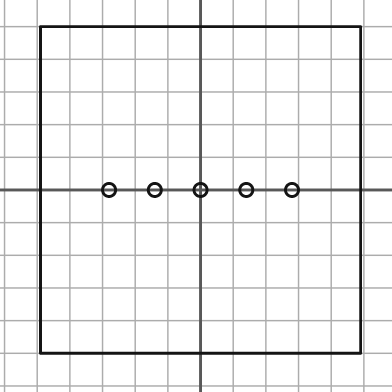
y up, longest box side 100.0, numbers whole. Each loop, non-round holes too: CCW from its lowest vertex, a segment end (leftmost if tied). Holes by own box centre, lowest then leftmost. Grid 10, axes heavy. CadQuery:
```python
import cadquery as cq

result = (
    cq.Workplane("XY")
    .moveTo(-49.0, -50.0)
    .lineTo(49.0, -50.0)
    .lineTo(49.0, 50.0)
    .lineTo(-49.0, 50.0)
    .close()
    .moveTo(-28.0, 0.0)
    .circle(2.0)
    .moveTo(-14.0, 0.0)
    .circle(2.0)
    .moveTo(0.0, 0.0)
    .circle(2.0)
    .moveTo(14.0, 0.0)
    .circle(2.0)
    .moveTo(28.0, 0.0)
    .circle(2.0)
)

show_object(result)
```